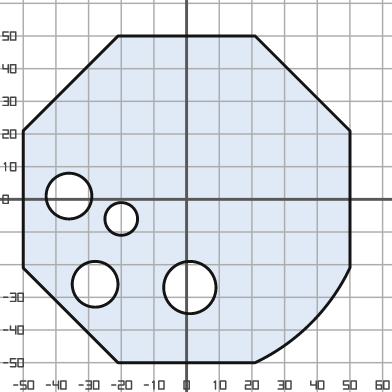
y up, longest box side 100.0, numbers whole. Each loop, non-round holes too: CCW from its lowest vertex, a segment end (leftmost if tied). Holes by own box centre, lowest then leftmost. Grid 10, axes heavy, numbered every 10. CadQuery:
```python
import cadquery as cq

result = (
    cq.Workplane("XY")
    .moveTo(-21.0, -50.0)
    .lineTo(21.0, -50.0)
    .threePointArc((38.0, -38.0), (50.0, -21.0))
    .lineTo(50.0, 21.0)
    .lineTo(21.0, 50.0)
    .lineTo(-21.0, 50.0)
    .lineTo(-50.0, 21.0)
    .lineTo(-50.0, -21.0)
    .close()
    .moveTo(1.0, -27.0)
    .circle(8.0)
    .moveTo(-28.0, -26.0)
    .circle(7.0)
    .moveTo(-20.0, -6.0)
    .circle(5.0)
    .moveTo(-36.0, 1.0)
    .circle(7.0)
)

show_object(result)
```